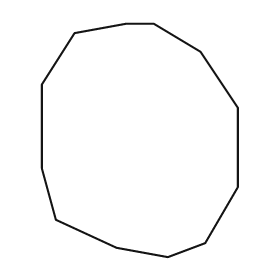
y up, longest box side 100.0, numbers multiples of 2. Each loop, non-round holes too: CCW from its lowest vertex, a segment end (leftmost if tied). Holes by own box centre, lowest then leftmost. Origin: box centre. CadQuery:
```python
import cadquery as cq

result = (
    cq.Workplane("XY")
    .moveTo(12.0, -50.0)
    .lineTo(28.0, -44.0)
    .lineTo(42.0, -20.0)
    .lineTo(42.0, 14.0)
    .lineTo(26.0, 38.0)
    .lineTo(6.0, 50.0)
    .lineTo(-6.0, 50.0)
    .lineTo(-28.0, 46.0)
    .lineTo(-42.0, 24.0)
    .lineTo(-42.0, -12.0)
    .lineTo(-36.0, -34.0)
    .lineTo(-10.0, -46.0)
    .close()
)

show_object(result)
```